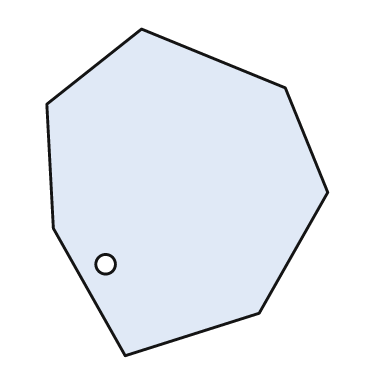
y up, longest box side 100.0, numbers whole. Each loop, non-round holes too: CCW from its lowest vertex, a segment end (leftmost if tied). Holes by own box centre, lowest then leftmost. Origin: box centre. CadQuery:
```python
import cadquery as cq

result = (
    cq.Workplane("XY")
    .moveTo(-19.0, -50.0)
    .lineTo(22.0, -37.0)
    .lineTo(43.0, 0.0)
    .lineTo(30.0, 32.0)
    .lineTo(-14.0, 50.0)
    .lineTo(-43.0, 27.0)
    .lineTo(-41.0, -11.0)
    .close()
    .moveTo(-25.0, -22.0)
    .circle(3.0)
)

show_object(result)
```